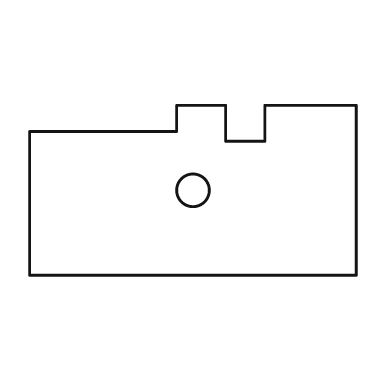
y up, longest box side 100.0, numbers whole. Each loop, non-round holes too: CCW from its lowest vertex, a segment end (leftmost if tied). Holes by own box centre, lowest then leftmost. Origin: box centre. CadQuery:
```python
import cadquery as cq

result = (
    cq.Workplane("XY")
    .moveTo(-50.0, -26.0)
    .lineTo(50.0, -26.0)
    .lineTo(50.0, 26.0)
    .lineTo(22.0, 26.0)
    .lineTo(22.0, 15.0)
    .lineTo(10.0, 15.0)
    .lineTo(10.0, 26.0)
    .lineTo(-5.0, 26.0)
    .lineTo(-5.0, 18.0)
    .lineTo(-50.0, 18.0)
    .close()
    .moveTo(0.0, 0.0)
    .circle(5.0)
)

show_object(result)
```